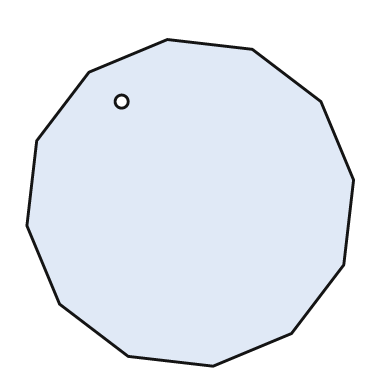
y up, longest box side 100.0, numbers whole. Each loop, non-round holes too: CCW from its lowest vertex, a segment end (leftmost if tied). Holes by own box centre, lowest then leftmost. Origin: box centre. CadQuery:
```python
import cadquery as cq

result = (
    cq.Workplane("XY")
    .moveTo(7.0, -50.0)
    .lineTo(31.0, -40.0)
    .lineTo(47.0, -19.0)
    .lineTo(50.0, 7.0)
    .lineTo(40.0, 31.0)
    .lineTo(19.0, 47.0)
    .lineTo(-7.0, 50.0)
    .lineTo(-31.0, 40.0)
    .lineTo(-47.0, 19.0)
    .lineTo(-50.0, -7.0)
    .lineTo(-40.0, -31.0)
    .lineTo(-19.0, -47.0)
    .close()
    .moveTo(-21.0, 31.0)
    .circle(2.0)
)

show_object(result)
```